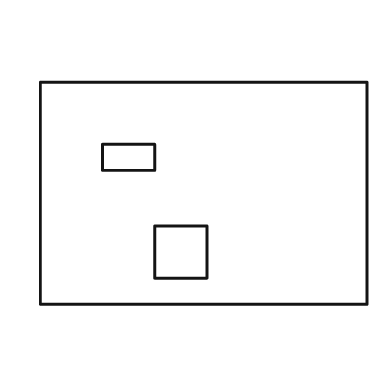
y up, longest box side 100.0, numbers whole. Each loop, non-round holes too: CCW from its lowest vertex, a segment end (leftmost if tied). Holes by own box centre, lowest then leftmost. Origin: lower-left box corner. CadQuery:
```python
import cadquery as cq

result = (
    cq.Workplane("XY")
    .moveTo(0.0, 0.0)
    .lineTo(100.0, 0.0)
    .lineTo(100.0, 68.0)
    .lineTo(0.0, 68.0)
    .close()
    .moveTo(35.0, 8.0)
    .lineTo(51.0, 8.0)
    .lineTo(51.0, 24.0)
    .lineTo(35.0, 24.0)
    .close()
    .moveTo(19.0, 41.0)
    .lineTo(35.0, 41.0)
    .lineTo(35.0, 49.0)
    .lineTo(19.0, 49.0)
    .close()
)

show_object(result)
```